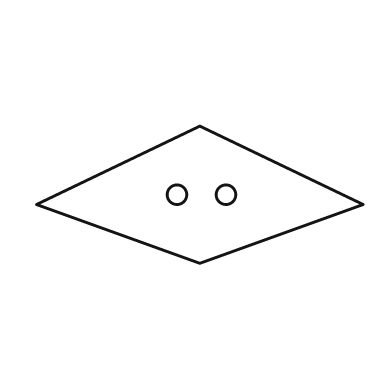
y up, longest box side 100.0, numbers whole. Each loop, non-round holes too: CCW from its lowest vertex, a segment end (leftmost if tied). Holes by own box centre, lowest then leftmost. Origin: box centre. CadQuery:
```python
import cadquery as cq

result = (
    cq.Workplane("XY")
    .moveTo(0.0, -21.0)
    .lineTo(50.0, -3.0)
    .lineTo(0.0, 21.0)
    .lineTo(-50.0, -3.0)
    .close()
    .moveTo(-7.0, 0.0)
    .circle(3.0)
    .moveTo(8.0, 0.0)
    .circle(3.0)
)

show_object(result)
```